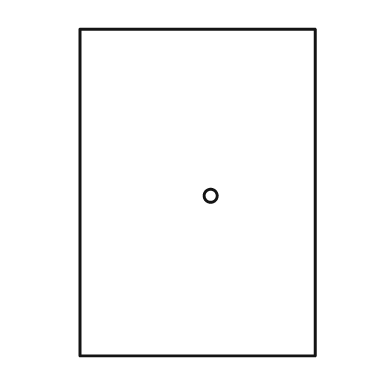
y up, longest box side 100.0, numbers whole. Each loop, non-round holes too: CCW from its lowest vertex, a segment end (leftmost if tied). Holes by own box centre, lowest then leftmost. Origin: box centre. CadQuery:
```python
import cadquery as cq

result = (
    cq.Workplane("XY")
    .moveTo(-36.0, -50.0)
    .lineTo(36.0, -50.0)
    .lineTo(36.0, 50.0)
    .lineTo(-36.0, 50.0)
    .close()
    .moveTo(4.0, -1.0)
    .circle(2.0)
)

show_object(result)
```